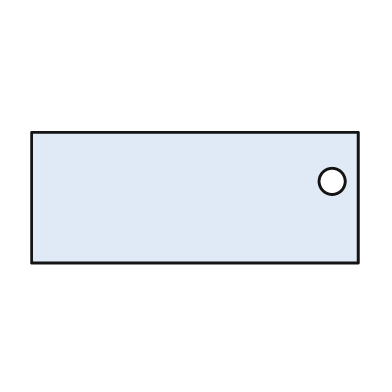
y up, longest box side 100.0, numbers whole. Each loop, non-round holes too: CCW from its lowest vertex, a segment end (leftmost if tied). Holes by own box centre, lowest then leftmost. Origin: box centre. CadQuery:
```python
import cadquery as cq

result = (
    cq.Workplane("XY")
    .moveTo(-50.0, -20.0)
    .lineTo(50.0, -20.0)
    .lineTo(50.0, 20.0)
    .lineTo(-50.0, 20.0)
    .close()
    .moveTo(42.0, 5.0)
    .circle(4.0)
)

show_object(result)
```